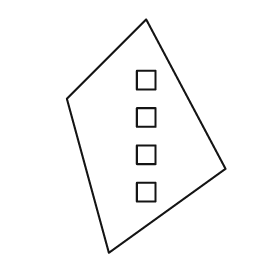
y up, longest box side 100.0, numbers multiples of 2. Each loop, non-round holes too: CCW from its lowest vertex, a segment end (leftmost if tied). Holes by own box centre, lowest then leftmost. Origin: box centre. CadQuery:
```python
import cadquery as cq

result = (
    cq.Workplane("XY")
    .moveTo(-16.0, -50.0)
    .lineTo(34.0, -14.0)
    .lineTo(0.0, 50.0)
    .lineTo(-34.0, 16.0)
    .close()
    .moveTo(-4.0, -28.0)
    .lineTo(4.0, -28.0)
    .lineTo(4.0, -20.0)
    .lineTo(-4.0, -20.0)
    .close()
    .moveTo(-4.0, -12.0)
    .lineTo(4.0, -12.0)
    .lineTo(4.0, -4.0)
    .lineTo(-4.0, -4.0)
    .close()
    .moveTo(-4.0, 4.0)
    .lineTo(4.0, 4.0)
    .lineTo(4.0, 12.0)
    .lineTo(-4.0, 12.0)
    .close()
    .moveTo(-4.0, 20.0)
    .lineTo(4.0, 20.0)
    .lineTo(4.0, 28.0)
    .lineTo(-4.0, 28.0)
    .close()
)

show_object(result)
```